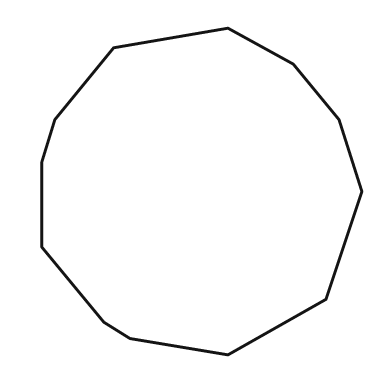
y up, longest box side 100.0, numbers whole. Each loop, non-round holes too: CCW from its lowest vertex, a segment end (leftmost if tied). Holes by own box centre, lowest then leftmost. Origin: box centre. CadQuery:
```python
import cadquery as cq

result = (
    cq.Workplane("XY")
    .moveTo(8.0, -50.0)
    .lineTo(38.0, -33.0)
    .lineTo(49.0, 0.0)
    .lineTo(42.0, 22.0)
    .lineTo(28.0, 39.0)
    .lineTo(8.0, 50.0)
    .lineTo(-27.0, 44.0)
    .lineTo(-45.0, 22.0)
    .lineTo(-49.0, 9.0)
    .lineTo(-49.0, -17.0)
    .lineTo(-30.0, -40.0)
    .lineTo(-22.0, -45.0)
    .close()
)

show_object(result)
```